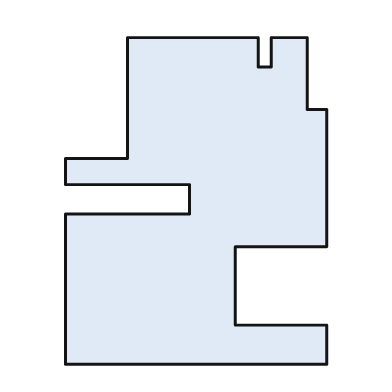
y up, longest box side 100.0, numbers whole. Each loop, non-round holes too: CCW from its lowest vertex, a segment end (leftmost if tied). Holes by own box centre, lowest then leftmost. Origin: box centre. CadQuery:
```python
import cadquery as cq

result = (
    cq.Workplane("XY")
    .moveTo(-40.0, -50.0)
    .lineTo(40.0, -50.0)
    .lineTo(40.0, -38.0)
    .lineTo(12.0, -38.0)
    .lineTo(12.0, -14.0)
    .lineTo(40.0, -14.0)
    .lineTo(40.0, 28.0)
    .lineTo(34.0, 28.0)
    .lineTo(34.0, 50.0)
    .lineTo(23.0, 50.0)
    .lineTo(23.0, 41.0)
    .lineTo(19.0, 41.0)
    .lineTo(19.0, 50.0)
    .lineTo(-21.0, 50.0)
    .lineTo(-21.0, 13.0)
    .lineTo(-40.0, 13.0)
    .lineTo(-40.0, 5.0)
    .lineTo(-2.0, 5.0)
    .lineTo(-2.0, -4.0)
    .lineTo(-40.0, -4.0)
    .close()
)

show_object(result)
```